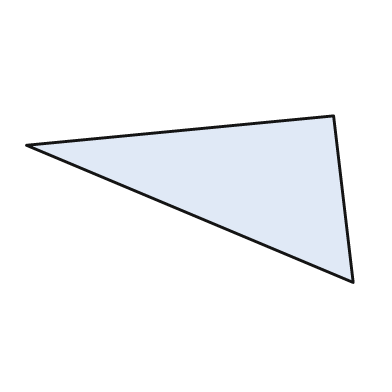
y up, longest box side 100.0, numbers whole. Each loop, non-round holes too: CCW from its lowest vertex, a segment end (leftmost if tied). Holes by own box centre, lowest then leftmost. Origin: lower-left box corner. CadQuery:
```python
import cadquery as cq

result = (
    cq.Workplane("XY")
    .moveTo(100.0, 0.0)
    .lineTo(94.0, 51.0)
    .lineTo(0.0, 42.0)
    .close()
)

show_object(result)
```